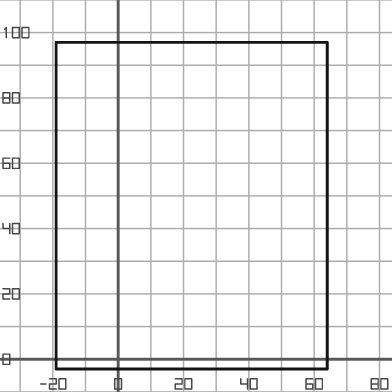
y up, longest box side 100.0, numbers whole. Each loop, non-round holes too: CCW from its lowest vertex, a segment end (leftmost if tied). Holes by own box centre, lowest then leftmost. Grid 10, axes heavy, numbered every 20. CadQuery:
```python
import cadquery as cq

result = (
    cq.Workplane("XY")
    .moveTo(-19.0, -3.0)
    .lineTo(64.0, -3.0)
    .lineTo(64.0, 97.0)
    .lineTo(-19.0, 97.0)
    .close()
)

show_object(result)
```